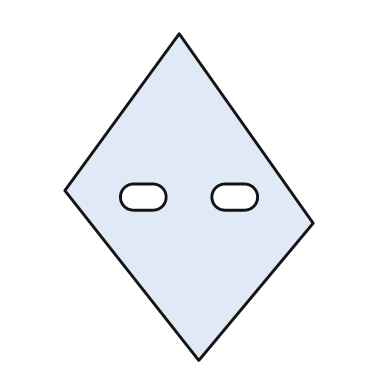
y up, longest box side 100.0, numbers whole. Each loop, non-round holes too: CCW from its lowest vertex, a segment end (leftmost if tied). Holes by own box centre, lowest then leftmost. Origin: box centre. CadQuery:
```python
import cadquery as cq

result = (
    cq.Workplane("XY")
    .moveTo(3.0, -50.0)
    .lineTo(38.0, -8.0)
    .lineTo(-3.0, 50.0)
    .lineTo(-38.0, 2.0)
    .close()
    .moveTo(-17.0, -4.0)
    .lineTo(-11.0, -4.0)
    .threePointArc((-7.0, 0.0), (-11.0, 4.0))
    .lineTo(-17.0, 4.0)
    .threePointArc((-21.0, 0.0), (-17.0, -4.0))
    .close()
    .moveTo(11.0, -4.0)
    .lineTo(17.0, -4.0)
    .threePointArc((21.0, 0.0), (17.0, 4.0))
    .lineTo(11.0, 4.0)
    .threePointArc((7.0, 0.0), (11.0, -4.0))
    .close()
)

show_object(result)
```